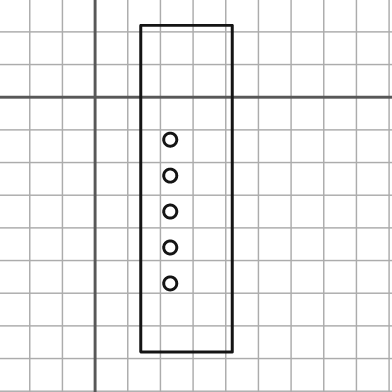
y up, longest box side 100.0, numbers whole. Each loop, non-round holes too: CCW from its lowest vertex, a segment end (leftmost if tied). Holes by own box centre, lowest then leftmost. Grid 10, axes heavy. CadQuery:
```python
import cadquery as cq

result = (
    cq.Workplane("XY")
    .moveTo(14.0, -78.0)
    .lineTo(42.0, -78.0)
    .lineTo(42.0, 22.0)
    .lineTo(14.0, 22.0)
    .close()
    .moveTo(23.0, -57.0)
    .circle(2.0)
    .moveTo(23.0, -46.0)
    .circle(2.0)
    .moveTo(23.0, -35.0)
    .circle(2.0)
    .moveTo(23.0, -24.0)
    .circle(2.0)
    .moveTo(23.0, -13.0)
    .circle(2.0)
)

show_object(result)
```